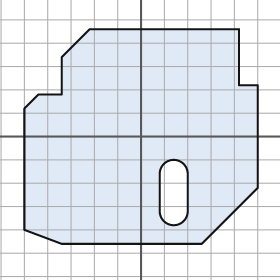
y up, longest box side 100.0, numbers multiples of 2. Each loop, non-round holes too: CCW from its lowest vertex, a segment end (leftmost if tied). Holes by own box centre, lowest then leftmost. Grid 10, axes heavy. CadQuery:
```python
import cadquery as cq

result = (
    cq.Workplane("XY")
    .moveTo(-34.0, -46.0)
    .lineTo(26.0, -46.0)
    .lineTo(50.0, -22.0)
    .lineTo(50.0, 22.0)
    .lineTo(42.0, 22.0)
    .lineTo(42.0, 46.0)
    .lineTo(-22.0, 46.0)
    .lineTo(-34.0, 34.0)
    .lineTo(-34.0, 18.0)
    .lineTo(-44.0, 18.0)
    .lineTo(-50.0, 12.0)
    .lineTo(-50.0, -40.0)
    .close()
    .moveTo(8.0, -32.0)
    .threePointArc((14.0, -38.0), (20.0, -32.0))
    .lineTo(20.0, -16.0)
    .threePointArc((14.0, -10.0), (8.0, -16.0))
    .close()
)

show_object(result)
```